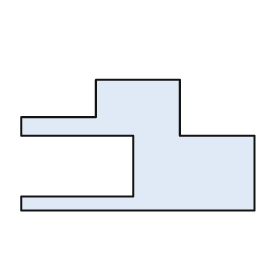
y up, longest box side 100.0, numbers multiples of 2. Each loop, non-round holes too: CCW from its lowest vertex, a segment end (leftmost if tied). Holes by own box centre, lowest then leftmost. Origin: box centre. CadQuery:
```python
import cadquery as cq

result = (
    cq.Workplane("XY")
    .moveTo(-50.0, -28.0)
    .lineTo(50.0, -28.0)
    .lineTo(50.0, 4.0)
    .lineTo(18.0, 4.0)
    .lineTo(18.0, 28.0)
    .lineTo(-18.0, 28.0)
    .lineTo(-18.0, 12.0)
    .lineTo(-50.0, 12.0)
    .lineTo(-50.0, 4.0)
    .lineTo(-2.0, 4.0)
    .lineTo(-2.0, -22.0)
    .lineTo(-50.0, -22.0)
    .close()
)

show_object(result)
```